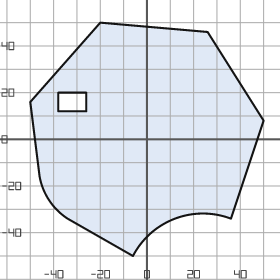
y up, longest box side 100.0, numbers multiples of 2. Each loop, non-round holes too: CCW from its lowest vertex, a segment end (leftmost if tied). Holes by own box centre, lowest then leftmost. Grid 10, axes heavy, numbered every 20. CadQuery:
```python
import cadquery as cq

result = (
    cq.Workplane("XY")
    .moveTo(-6.0, -50.0)
    .threePointArc((12.0, -34.0), (36.0, -34.0))
    .lineTo(50.0, 8.0)
    .lineTo(26.0, 46.0)
    .lineTo(-20.0, 50.0)
    .lineTo(-50.0, 16.0)
    .lineTo(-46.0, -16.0)
    .threePointArc((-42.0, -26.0), (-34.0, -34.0))
    .close()
    .moveTo(-38.0, 12.0)
    .lineTo(-26.0, 12.0)
    .lineTo(-26.0, 20.0)
    .lineTo(-38.0, 20.0)
    .close()
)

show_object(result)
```